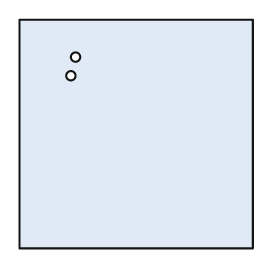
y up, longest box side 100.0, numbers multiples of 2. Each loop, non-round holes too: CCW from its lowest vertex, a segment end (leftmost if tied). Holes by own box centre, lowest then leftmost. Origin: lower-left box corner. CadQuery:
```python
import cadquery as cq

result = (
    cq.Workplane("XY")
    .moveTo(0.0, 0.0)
    .lineTo(100.0, 0.0)
    .lineTo(100.0, 98.0)
    .lineTo(0.0, 98.0)
    .close()
    .moveTo(22.0, 74.0)
    .circle(2.0)
    .moveTo(24.0, 82.0)
    .circle(2.0)
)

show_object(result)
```